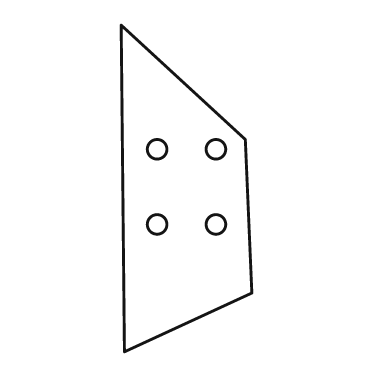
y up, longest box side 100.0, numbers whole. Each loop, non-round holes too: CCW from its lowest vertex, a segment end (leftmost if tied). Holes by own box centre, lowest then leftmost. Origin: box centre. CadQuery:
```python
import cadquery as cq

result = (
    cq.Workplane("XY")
    .moveTo(-19.0, -50.0)
    .lineTo(20.0, -32.0)
    .lineTo(18.0, 15.0)
    .lineTo(-20.0, 50.0)
    .close()
    .moveTo(-9.0, -11.0)
    .circle(3.0)
    .moveTo(9.0, -11.0)
    .circle(3.0)
    .moveTo(-9.0, 12.0)
    .circle(3.0)
    .moveTo(9.0, 12.0)
    .circle(3.0)
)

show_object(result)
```